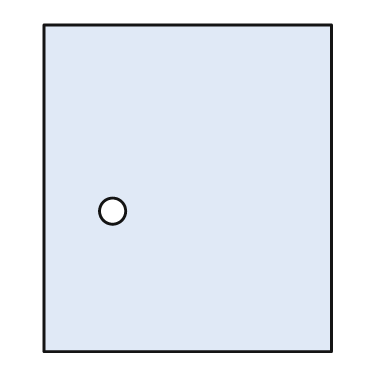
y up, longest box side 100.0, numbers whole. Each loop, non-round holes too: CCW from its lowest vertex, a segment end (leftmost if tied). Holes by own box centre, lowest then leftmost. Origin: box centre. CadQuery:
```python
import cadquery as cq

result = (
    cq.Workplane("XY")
    .moveTo(-44.0, -50.0)
    .lineTo(44.0, -50.0)
    .lineTo(44.0, 50.0)
    .lineTo(-44.0, 50.0)
    .close()
    .moveTo(-23.0, -7.0)
    .circle(4.0)
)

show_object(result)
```